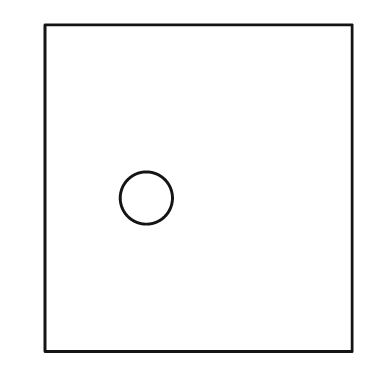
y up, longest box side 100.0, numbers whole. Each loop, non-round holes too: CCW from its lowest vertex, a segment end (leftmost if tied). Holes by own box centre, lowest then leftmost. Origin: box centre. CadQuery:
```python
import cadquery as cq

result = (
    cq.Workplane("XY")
    .moveTo(-47.0, -50.0)
    .lineTo(47.0, -50.0)
    .lineTo(47.0, 50.0)
    .lineTo(-47.0, 50.0)
    .close()
    .moveTo(-16.0, -3.0)
    .circle(8.0)
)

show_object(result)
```